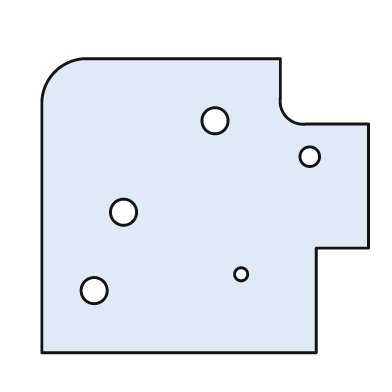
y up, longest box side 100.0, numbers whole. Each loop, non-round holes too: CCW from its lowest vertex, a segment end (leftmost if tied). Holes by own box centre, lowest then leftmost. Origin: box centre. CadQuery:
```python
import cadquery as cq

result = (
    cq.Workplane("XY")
    .moveTo(-50.0, -45.0)
    .lineTo(34.0, -45.0)
    .lineTo(34.0, -13.0)
    .lineTo(50.0, -13.0)
    .lineTo(50.0, 25.0)
    .lineTo(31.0, 25.0)
    .threePointArc((25.0, 27.0), (23.0, 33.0))
    .lineTo(23.0, 45.0)
    .lineTo(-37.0, 45.0)
    .threePointArc((-46.0, 41.0), (-50.0, 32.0))
    .close()
    .moveTo(-34.0, -26.0)
    .circle(4.0)
    .moveTo(11.0, -21.0)
    .circle(2.0)
    .moveTo(-25.0, -2.0)
    .circle(4.0)
    .moveTo(32.0, 15.0)
    .circle(3.0)
    .moveTo(3.0, 26.0)
    .circle(4.0)
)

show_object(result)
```